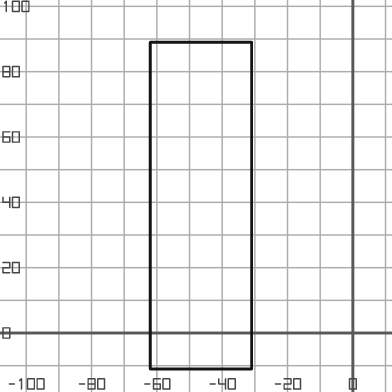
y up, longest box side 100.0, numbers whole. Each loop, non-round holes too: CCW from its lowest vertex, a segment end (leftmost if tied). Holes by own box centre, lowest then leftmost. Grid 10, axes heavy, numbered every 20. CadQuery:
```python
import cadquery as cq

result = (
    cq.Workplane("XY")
    .moveTo(-62.0, -11.0)
    .lineTo(-31.0, -11.0)
    .lineTo(-31.0, 89.0)
    .lineTo(-62.0, 89.0)
    .close()
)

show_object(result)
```